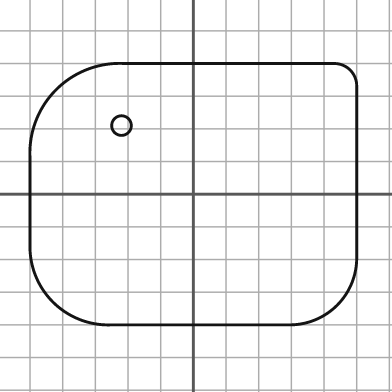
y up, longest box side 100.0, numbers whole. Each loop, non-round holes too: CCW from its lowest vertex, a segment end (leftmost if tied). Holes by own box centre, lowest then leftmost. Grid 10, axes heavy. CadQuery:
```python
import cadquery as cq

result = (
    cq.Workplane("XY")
    .moveTo(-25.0, -40.0)
    .lineTo(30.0, -40.0)
    .threePointArc((44.0, -34.0), (50.0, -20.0))
    .lineTo(50.0, 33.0)
    .threePointArc((48.0, 38.0), (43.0, 40.0))
    .lineTo(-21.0, 40.0)
    .threePointArc((-42.0, 32.0), (-50.0, 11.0))
    .lineTo(-50.0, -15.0)
    .threePointArc((-43.0, -33.0), (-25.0, -40.0))
    .close()
    .moveTo(-22.0, 21.0)
    .circle(3.0)
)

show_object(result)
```